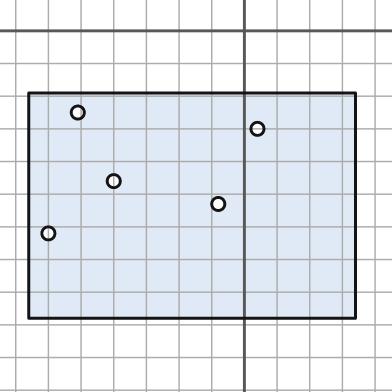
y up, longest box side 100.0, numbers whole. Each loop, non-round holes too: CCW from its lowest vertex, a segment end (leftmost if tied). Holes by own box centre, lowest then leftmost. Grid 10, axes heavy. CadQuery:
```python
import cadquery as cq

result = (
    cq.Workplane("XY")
    .moveTo(-66.0, -88.0)
    .lineTo(34.0, -88.0)
    .lineTo(34.0, -19.0)
    .lineTo(-66.0, -19.0)
    .close()
    .moveTo(-60.0, -62.0)
    .circle(2.0)
    .moveTo(-8.0, -53.0)
    .circle(2.0)
    .moveTo(-40.0, -46.0)
    .circle(2.0)
    .moveTo(4.0, -30.0)
    .circle(2.0)
    .moveTo(-51.0, -25.0)
    .circle(2.0)
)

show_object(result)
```